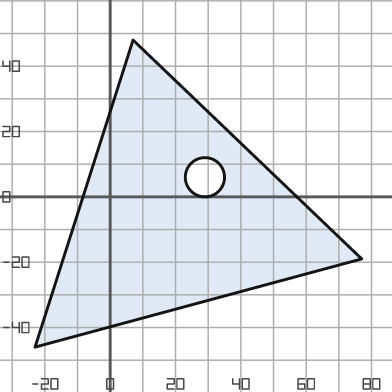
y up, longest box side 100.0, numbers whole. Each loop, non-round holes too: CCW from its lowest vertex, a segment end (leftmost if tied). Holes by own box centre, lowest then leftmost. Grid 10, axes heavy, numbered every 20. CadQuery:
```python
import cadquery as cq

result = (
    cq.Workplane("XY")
    .moveTo(-23.0, -46.0)
    .lineTo(77.0, -19.0)
    .lineTo(7.0, 48.0)
    .close()
    .moveTo(29.0, 6.0)
    .circle(6.0)
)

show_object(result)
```